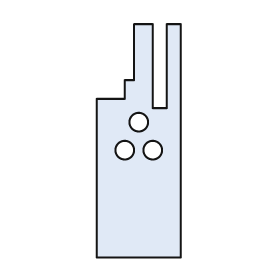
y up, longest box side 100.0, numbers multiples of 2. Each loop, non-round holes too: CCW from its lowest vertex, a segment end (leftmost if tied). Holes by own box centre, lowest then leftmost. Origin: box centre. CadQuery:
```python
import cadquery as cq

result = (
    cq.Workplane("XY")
    .moveTo(-18.0, -50.0)
    .lineTo(18.0, -50.0)
    .lineTo(18.0, 50.0)
    .lineTo(12.0, 50.0)
    .lineTo(12.0, 14.0)
    .lineTo(6.0, 14.0)
    .lineTo(6.0, 50.0)
    .lineTo(-2.0, 50.0)
    .lineTo(-2.0, 26.0)
    .lineTo(-6.0, 26.0)
    .lineTo(-6.0, 18.0)
    .lineTo(-18.0, 18.0)
    .close()
    .moveTo(-6.0, -4.0)
    .circle(4.0)
    .moveTo(6.0, -4.0)
    .circle(4.0)
    .moveTo(0.0, 8.0)
    .circle(4.0)
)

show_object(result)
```